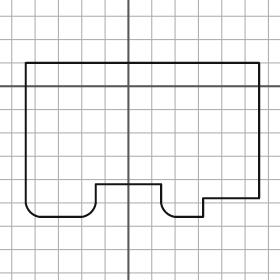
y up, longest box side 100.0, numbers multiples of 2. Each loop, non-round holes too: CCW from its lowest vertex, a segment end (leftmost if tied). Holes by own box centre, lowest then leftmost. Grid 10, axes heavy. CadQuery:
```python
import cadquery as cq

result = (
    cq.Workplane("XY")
    .moveTo(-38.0, -56.0)
    .lineTo(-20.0, -56.0)
    .threePointArc((-16.0, -54.0), (-14.0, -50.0))
    .lineTo(-14.0, -42.0)
    .lineTo(14.0, -42.0)
    .lineTo(14.0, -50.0)
    .threePointArc((16.0, -54.0), (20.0, -56.0))
    .lineTo(32.0, -56.0)
    .lineTo(32.0, -48.0)
    .lineTo(56.0, -48.0)
    .lineTo(56.0, 10.0)
    .lineTo(-44.0, 10.0)
    .lineTo(-44.0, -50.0)
    .threePointArc((-42.0, -54.0), (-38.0, -56.0))
    .close()
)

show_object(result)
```